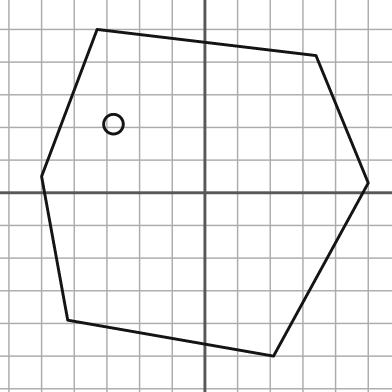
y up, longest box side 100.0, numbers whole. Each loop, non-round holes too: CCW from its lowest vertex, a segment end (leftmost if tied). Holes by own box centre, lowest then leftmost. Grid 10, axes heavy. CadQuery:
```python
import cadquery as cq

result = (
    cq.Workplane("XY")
    .moveTo(21.0, -50.0)
    .lineTo(50.0, 3.0)
    .lineTo(34.0, 42.0)
    .lineTo(-33.0, 50.0)
    .lineTo(-50.0, 5.0)
    .lineTo(-42.0, -39.0)
    .close()
    .moveTo(-28.0, 21.0)
    .circle(3.0)
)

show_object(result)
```